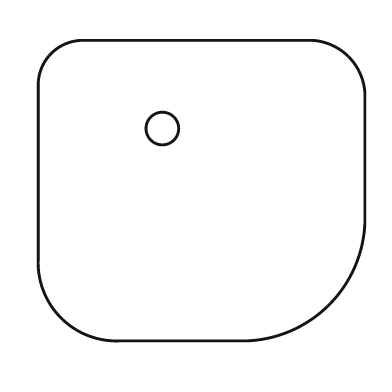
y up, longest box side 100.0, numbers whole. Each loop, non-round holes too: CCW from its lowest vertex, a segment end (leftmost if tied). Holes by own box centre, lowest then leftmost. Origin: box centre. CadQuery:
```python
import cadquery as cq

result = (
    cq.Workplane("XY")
    .moveTo(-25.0, -46.0)
    .lineTo(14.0, -46.0)
    .threePointArc((39.0, -35.0), (50.0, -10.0))
    .lineTo(50.0, 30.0)
    .threePointArc((45.0, 41.0), (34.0, 46.0))
    .lineTo(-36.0, 46.0)
    .threePointArc((-46.0, 42.0), (-50.0, 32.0))
    .lineTo(-50.0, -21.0)
    .threePointArc((-43.0, -39.0), (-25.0, -46.0))
    .close()
    .moveTo(-12.0, 19.0)
    .circle(5.0)
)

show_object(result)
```